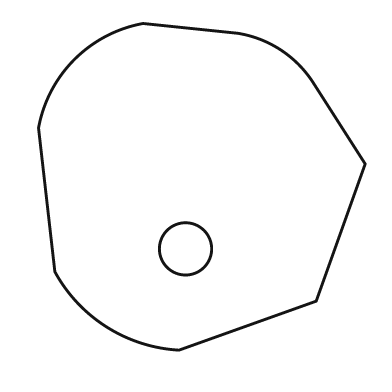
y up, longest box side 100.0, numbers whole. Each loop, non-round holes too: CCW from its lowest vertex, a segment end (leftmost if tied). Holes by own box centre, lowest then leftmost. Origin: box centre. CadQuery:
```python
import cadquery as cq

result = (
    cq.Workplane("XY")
    .moveTo(-7.0, -50.0)
    .lineTo(35.0, -35.0)
    .lineTo(50.0, 7.0)
    .lineTo(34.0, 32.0)
    .threePointArc((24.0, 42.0), (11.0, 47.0))
    .lineTo(-18.0, 50.0)
    .threePointArc((-39.0, 39.0), (-50.0, 18.0))
    .lineTo(-45.0, -26.0)
    .threePointArc((-29.0, -43.0), (-7.0, -50.0))
    .close()
    .moveTo(-5.0, -19.0)
    .circle(8.0)
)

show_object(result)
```